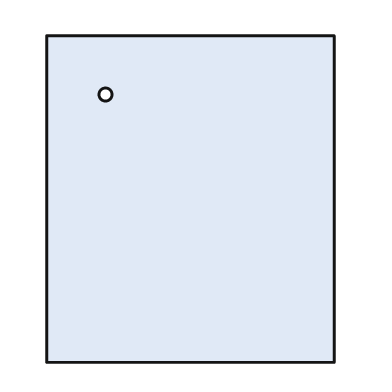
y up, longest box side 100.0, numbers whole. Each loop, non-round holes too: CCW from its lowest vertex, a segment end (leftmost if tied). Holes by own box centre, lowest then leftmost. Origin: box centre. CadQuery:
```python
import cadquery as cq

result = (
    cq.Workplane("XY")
    .moveTo(-44.0, -50.0)
    .lineTo(44.0, -50.0)
    .lineTo(44.0, 50.0)
    .lineTo(-44.0, 50.0)
    .close()
    .moveTo(-26.0, 32.0)
    .circle(2.0)
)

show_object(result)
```